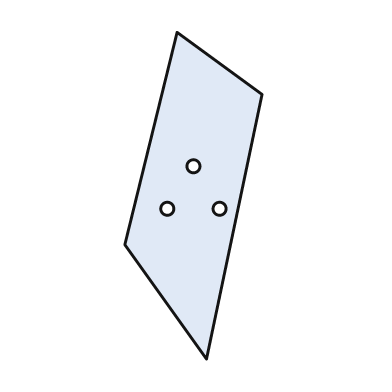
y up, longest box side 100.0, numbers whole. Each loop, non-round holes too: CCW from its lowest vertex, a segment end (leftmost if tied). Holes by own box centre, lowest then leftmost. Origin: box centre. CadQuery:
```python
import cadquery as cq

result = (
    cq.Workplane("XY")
    .moveTo(4.0, -50.0)
    .lineTo(21.0, 31.0)
    .lineTo(-5.0, 50.0)
    .lineTo(-21.0, -15.0)
    .close()
    .moveTo(-8.0, -4.0)
    .circle(2.0)
    .moveTo(8.0, -4.0)
    .circle(2.0)
    .moveTo(0.0, 9.0)
    .circle(2.0)
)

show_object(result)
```